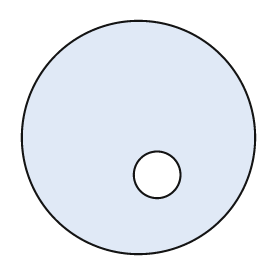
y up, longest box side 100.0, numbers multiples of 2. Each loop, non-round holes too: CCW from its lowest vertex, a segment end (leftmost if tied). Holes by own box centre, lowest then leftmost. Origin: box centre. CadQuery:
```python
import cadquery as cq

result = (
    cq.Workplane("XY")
    .moveTo(0.0, 0.0)
    .circle(50.0)
    .moveTo(8.0, -16.0)
    .circle(10.0)
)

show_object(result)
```